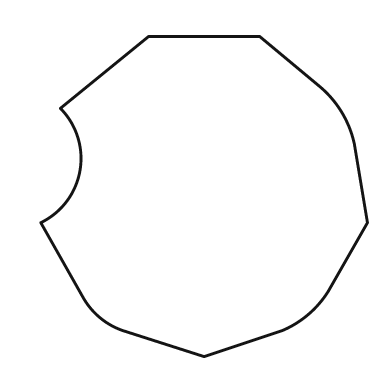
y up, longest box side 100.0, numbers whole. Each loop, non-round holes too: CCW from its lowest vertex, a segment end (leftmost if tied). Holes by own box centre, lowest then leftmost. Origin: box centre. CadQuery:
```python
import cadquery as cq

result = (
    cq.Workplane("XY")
    .moveTo(0.0, -49.0)
    .lineTo(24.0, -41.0)
    .threePointArc((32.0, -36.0), (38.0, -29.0))
    .lineTo(50.0, -8.0)
    .lineTo(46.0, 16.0)
    .threePointArc((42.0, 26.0), (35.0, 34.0))
    .lineTo(17.0, 49.0)
    .lineTo(-17.0, 49.0)
    .lineTo(-44.0, 27.0)
    .threePointArc((-38.0, 8.0), (-50.0, -8.0))
    .lineTo(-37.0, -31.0)
    .threePointArc((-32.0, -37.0), (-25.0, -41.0))
    .close()
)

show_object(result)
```